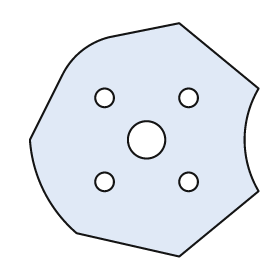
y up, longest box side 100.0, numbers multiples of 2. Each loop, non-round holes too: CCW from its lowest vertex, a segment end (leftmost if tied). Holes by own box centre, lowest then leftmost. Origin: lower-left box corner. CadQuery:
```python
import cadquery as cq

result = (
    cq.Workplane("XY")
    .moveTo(64.0, 0.0)
    .lineTo(98.0, 28.0)
    .threePointArc((92.0, 50.0), (98.0, 72.0))
    .lineTo(64.0, 100.0)
    .lineTo(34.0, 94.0)
    .threePointArc((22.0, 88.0), (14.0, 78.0))
    .lineTo(0.0, 50.0)
    .threePointArc((6.0, 28.0), (20.0, 10.0))
    .close()
    .moveTo(32.0, 32.0)
    .circle(4.0)
    .moveTo(68.0, 32.0)
    .circle(4.0)
    .moveTo(50.0, 50.0)
    .circle(8.0)
    .moveTo(32.0, 68.0)
    .circle(4.0)
    .moveTo(68.0, 68.0)
    .circle(4.0)
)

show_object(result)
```